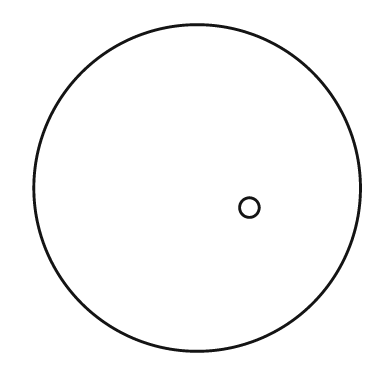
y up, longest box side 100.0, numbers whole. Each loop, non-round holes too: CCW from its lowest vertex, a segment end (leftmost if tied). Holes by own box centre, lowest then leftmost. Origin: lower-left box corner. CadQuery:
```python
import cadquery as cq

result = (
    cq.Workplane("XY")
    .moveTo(50.0, 50.0)
    .circle(50.0)
    .moveTo(66.0, 44.0)
    .circle(3.0)
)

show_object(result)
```